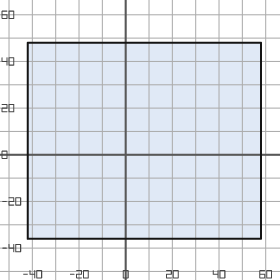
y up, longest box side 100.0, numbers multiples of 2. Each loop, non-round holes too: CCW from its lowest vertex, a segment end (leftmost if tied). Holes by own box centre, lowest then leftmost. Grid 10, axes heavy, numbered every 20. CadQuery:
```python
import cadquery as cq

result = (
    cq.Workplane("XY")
    .moveTo(-42.0, -36.0)
    .lineTo(58.0, -36.0)
    .lineTo(58.0, 48.0)
    .lineTo(-42.0, 48.0)
    .close()
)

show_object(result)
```